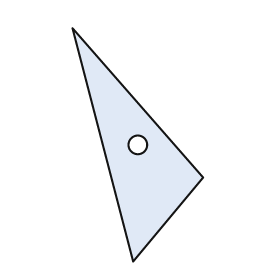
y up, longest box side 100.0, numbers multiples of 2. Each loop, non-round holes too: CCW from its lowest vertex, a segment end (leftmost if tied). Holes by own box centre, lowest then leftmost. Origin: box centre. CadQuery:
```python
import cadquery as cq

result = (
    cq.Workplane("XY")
    .moveTo(-2.0, -50.0)
    .lineTo(28.0, -14.0)
    .lineTo(-28.0, 50.0)
    .close()
    .moveTo(0.0, 0.0)
    .circle(4.0)
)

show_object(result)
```